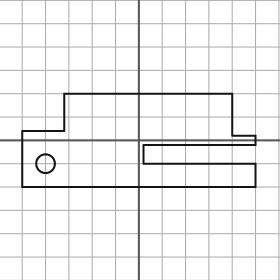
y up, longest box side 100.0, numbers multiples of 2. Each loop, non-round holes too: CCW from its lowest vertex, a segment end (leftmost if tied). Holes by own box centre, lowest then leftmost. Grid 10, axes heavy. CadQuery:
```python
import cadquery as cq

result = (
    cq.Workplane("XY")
    .moveTo(-50.0, -20.0)
    .lineTo(50.0, -20.0)
    .lineTo(50.0, -10.0)
    .lineTo(2.0, -10.0)
    .lineTo(2.0, -2.0)
    .lineTo(50.0, -2.0)
    .lineTo(50.0, 2.0)
    .lineTo(40.0, 2.0)
    .lineTo(40.0, 20.0)
    .lineTo(-32.0, 20.0)
    .lineTo(-32.0, 4.0)
    .lineTo(-50.0, 4.0)
    .close()
    .moveTo(-40.0, -10.0)
    .circle(4.0)
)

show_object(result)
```